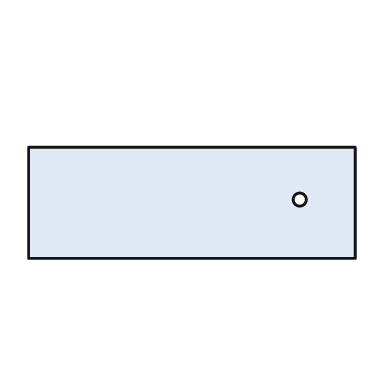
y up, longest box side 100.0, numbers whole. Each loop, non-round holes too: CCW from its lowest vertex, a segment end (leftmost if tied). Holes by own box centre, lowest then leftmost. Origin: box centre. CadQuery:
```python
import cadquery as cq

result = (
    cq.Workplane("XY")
    .moveTo(-50.0, -17.0)
    .lineTo(50.0, -17.0)
    .lineTo(50.0, 17.0)
    .lineTo(-50.0, 17.0)
    .close()
    .moveTo(33.0, 1.0)
    .circle(2.0)
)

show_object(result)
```